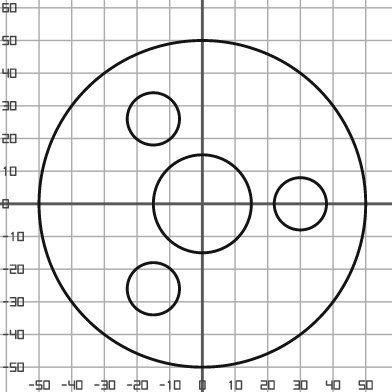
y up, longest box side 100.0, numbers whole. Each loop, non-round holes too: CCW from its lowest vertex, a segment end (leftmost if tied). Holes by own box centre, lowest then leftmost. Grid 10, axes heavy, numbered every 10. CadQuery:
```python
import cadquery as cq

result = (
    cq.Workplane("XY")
    .moveTo(0.0, 0.0)
    .circle(50.0)
    .moveTo(-15.0, -26.0)
    .circle(8.0)
    .moveTo(0.0, 0.0)
    .circle(15.0)
    .moveTo(30.0, 0.0)
    .circle(8.0)
    .moveTo(-15.0, 26.0)
    .circle(8.0)
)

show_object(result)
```